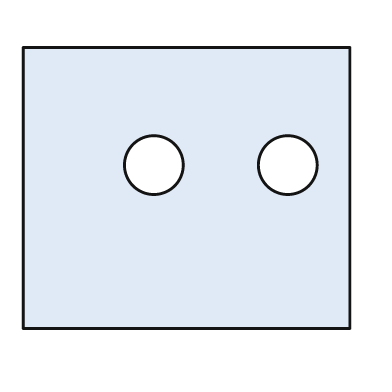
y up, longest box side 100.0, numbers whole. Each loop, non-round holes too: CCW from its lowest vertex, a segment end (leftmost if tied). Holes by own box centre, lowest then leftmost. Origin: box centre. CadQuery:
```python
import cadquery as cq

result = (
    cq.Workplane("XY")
    .moveTo(-50.0, -43.0)
    .lineTo(50.0, -43.0)
    .lineTo(50.0, 43.0)
    .lineTo(-50.0, 43.0)
    .close()
    .moveTo(-10.0, 7.0)
    .circle(9.0)
    .moveTo(31.0, 7.0)
    .circle(9.0)
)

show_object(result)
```